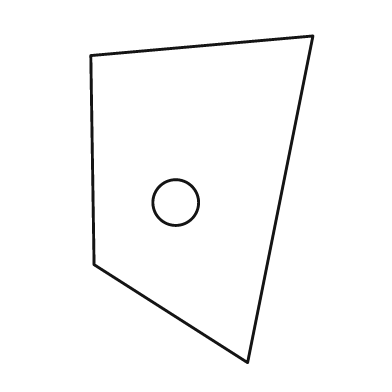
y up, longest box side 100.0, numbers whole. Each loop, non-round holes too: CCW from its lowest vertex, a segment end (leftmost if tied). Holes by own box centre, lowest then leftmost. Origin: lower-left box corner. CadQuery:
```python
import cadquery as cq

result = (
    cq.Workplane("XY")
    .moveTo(48.0, 0.0)
    .lineTo(68.0, 100.0)
    .lineTo(0.0, 94.0)
    .lineTo(1.0, 30.0)
    .close()
    .moveTo(26.0, 49.0)
    .circle(7.0)
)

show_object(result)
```